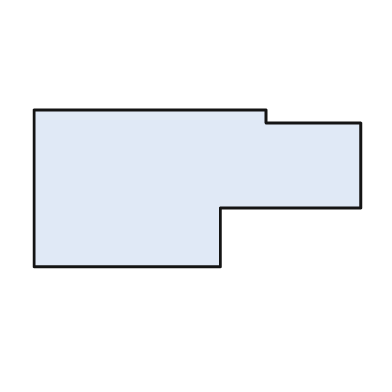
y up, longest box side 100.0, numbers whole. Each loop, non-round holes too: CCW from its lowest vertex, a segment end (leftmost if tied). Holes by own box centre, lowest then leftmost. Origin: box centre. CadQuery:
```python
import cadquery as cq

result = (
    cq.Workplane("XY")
    .moveTo(-50.0, -24.0)
    .lineTo(7.0, -24.0)
    .lineTo(7.0, -6.0)
    .lineTo(50.0, -6.0)
    .lineTo(50.0, 20.0)
    .lineTo(21.0, 20.0)
    .lineTo(21.0, 24.0)
    .lineTo(-50.0, 24.0)
    .close()
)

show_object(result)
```